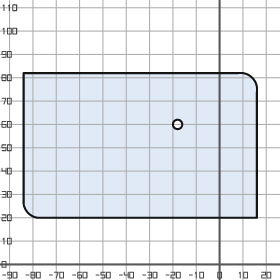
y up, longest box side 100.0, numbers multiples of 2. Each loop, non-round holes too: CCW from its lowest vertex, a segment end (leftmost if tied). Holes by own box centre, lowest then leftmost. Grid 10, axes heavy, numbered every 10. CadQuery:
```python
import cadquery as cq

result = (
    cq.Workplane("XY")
    .moveTo(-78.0, 20.0)
    .lineTo(16.0, 20.0)
    .lineTo(16.0, 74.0)
    .threePointArc((14.0, 80.0), (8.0, 82.0))
    .lineTo(-84.0, 82.0)
    .lineTo(-84.0, 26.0)
    .threePointArc((-82.0, 22.0), (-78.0, 20.0))
    .close()
    .moveTo(-18.0, 60.0)
    .circle(2.0)
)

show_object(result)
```